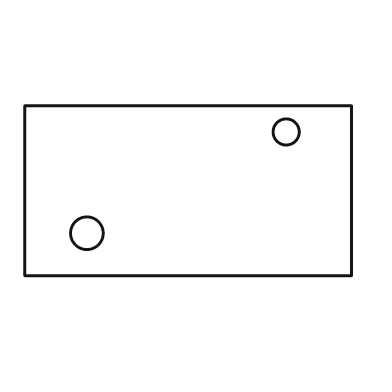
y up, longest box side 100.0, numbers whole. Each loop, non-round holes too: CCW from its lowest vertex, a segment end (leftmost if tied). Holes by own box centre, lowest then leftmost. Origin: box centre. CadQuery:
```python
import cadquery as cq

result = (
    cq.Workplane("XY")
    .moveTo(-50.0, -26.0)
    .lineTo(50.0, -26.0)
    .lineTo(50.0, 26.0)
    .lineTo(-50.0, 26.0)
    .close()
    .moveTo(-31.0, -13.0)
    .circle(5.0)
    .moveTo(30.0, 18.0)
    .circle(4.0)
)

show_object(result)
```